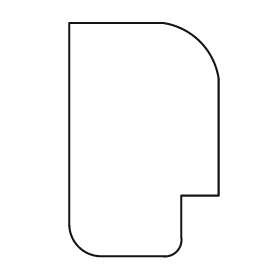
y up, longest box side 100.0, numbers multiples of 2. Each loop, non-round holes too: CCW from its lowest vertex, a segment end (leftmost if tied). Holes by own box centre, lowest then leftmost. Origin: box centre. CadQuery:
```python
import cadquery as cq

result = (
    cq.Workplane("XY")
    .moveTo(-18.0, -50.0)
    .lineTo(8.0, -50.0)
    .threePointArc((14.0, -48.0), (16.0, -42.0))
    .lineTo(16.0, -24.0)
    .lineTo(32.0, -24.0)
    .lineTo(32.0, 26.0)
    .threePointArc((24.0, 42.0), (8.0, 50.0))
    .lineTo(-32.0, 50.0)
    .lineTo(-32.0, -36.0)
    .threePointArc((-28.0, -46.0), (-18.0, -50.0))
    .close()
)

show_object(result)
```